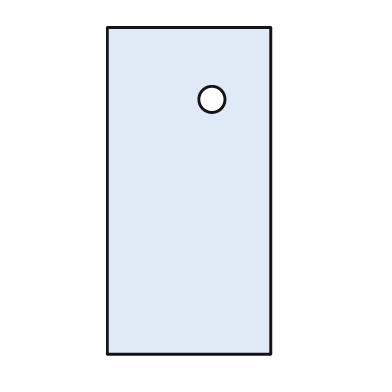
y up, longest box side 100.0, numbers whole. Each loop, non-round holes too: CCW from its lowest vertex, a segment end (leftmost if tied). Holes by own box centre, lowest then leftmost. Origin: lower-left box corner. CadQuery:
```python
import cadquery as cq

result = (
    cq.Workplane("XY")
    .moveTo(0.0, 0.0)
    .lineTo(50.0, 0.0)
    .lineTo(50.0, 100.0)
    .lineTo(0.0, 100.0)
    .close()
    .moveTo(32.0, 78.0)
    .circle(4.0)
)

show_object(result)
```